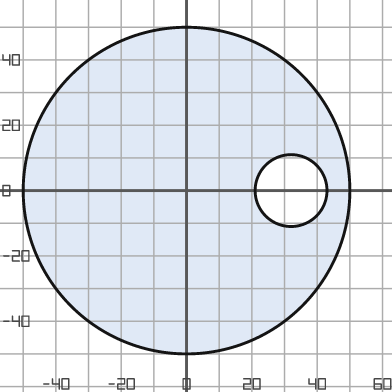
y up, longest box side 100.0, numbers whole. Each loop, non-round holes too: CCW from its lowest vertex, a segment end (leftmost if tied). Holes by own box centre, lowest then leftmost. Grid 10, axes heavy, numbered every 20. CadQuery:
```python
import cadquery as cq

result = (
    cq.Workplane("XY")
    .moveTo(0.0, 0.0)
    .circle(50.0)
    .moveTo(32.0, 0.0)
    .circle(11.0)
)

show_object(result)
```